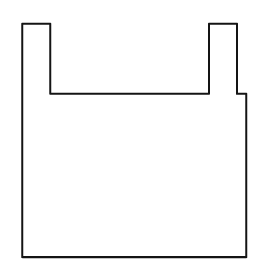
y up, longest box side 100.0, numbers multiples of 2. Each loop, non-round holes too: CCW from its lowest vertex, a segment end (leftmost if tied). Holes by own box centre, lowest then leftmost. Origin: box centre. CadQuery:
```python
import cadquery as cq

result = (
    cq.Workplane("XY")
    .moveTo(-48.0, -50.0)
    .lineTo(48.0, -50.0)
    .lineTo(48.0, 20.0)
    .lineTo(44.0, 20.0)
    .lineTo(44.0, 50.0)
    .lineTo(32.0, 50.0)
    .lineTo(32.0, 20.0)
    .lineTo(-36.0, 20.0)
    .lineTo(-36.0, 50.0)
    .lineTo(-48.0, 50.0)
    .close()
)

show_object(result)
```